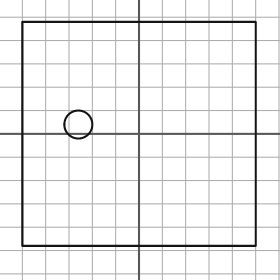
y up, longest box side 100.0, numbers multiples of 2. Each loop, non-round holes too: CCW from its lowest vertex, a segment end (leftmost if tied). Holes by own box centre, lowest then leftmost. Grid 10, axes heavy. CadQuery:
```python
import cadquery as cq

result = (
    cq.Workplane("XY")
    .moveTo(-50.0, -48.0)
    .lineTo(50.0, -48.0)
    .lineTo(50.0, 48.0)
    .lineTo(-50.0, 48.0)
    .close()
    .moveTo(-26.0, 4.0)
    .circle(6.0)
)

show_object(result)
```